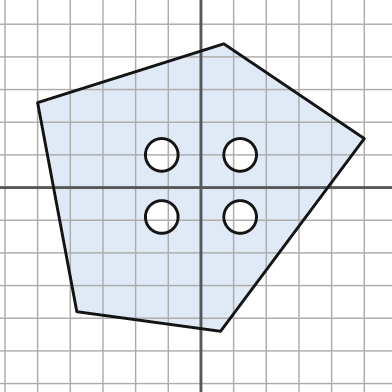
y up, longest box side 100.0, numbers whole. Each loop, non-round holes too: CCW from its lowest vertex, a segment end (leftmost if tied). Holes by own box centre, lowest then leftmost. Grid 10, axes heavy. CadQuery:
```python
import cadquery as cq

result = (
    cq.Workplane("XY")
    .moveTo(6.0, -44.0)
    .lineTo(50.0, 15.0)
    .lineTo(7.0, 44.0)
    .lineTo(-50.0, 26.0)
    .lineTo(-38.0, -38.0)
    .close()
    .moveTo(-12.0, -9.0)
    .circle(5.0)
    .moveTo(12.0, -9.0)
    .circle(5.0)
    .moveTo(-12.0, 10.0)
    .circle(5.0)
    .moveTo(12.0, 10.0)
    .circle(5.0)
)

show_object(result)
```